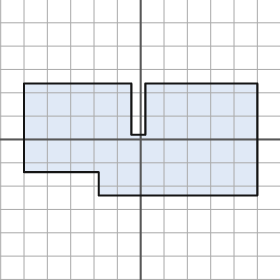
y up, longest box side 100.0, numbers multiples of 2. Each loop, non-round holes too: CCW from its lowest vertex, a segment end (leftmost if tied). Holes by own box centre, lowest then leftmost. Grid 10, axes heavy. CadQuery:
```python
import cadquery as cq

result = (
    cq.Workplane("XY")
    .moveTo(-18.0, -24.0)
    .lineTo(50.0, -24.0)
    .lineTo(50.0, 24.0)
    .lineTo(2.0, 24.0)
    .lineTo(2.0, 2.0)
    .lineTo(-4.0, 2.0)
    .lineTo(-4.0, 24.0)
    .lineTo(-50.0, 24.0)
    .lineTo(-50.0, -14.0)
    .lineTo(-18.0, -14.0)
    .close()
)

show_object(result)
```